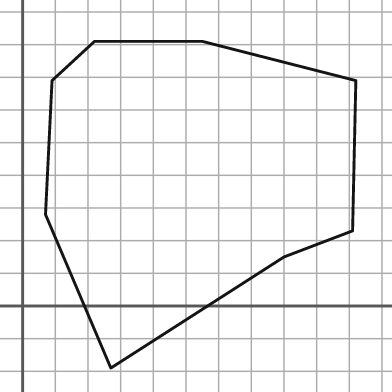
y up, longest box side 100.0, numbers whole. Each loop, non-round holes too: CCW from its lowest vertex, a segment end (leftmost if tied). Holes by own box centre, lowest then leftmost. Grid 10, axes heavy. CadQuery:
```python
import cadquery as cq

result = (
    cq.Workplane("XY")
    .moveTo(27.0, -19.0)
    .lineTo(80.0, 15.0)
    .lineTo(101.0, 23.0)
    .lineTo(102.0, 69.0)
    .lineTo(55.0, 81.0)
    .lineTo(22.0, 81.0)
    .lineTo(9.0, 69.0)
    .lineTo(7.0, 28.0)
    .close()
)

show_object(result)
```